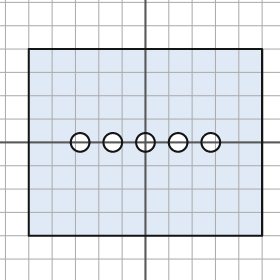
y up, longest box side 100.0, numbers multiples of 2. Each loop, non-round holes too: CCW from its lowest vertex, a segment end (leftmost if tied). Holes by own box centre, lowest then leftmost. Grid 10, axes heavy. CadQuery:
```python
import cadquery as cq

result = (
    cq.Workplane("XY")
    .moveTo(-50.0, -40.0)
    .lineTo(50.0, -40.0)
    .lineTo(50.0, 40.0)
    .lineTo(-50.0, 40.0)
    .close()
    .moveTo(-28.0, 0.0)
    .circle(4.0)
    .moveTo(-14.0, 0.0)
    .circle(4.0)
    .moveTo(0.0, 0.0)
    .circle(4.0)
    .moveTo(14.0, 0.0)
    .circle(4.0)
    .moveTo(28.0, 0.0)
    .circle(4.0)
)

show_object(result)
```